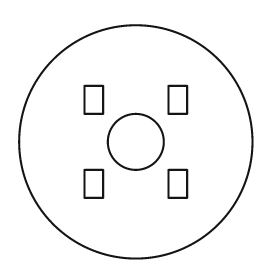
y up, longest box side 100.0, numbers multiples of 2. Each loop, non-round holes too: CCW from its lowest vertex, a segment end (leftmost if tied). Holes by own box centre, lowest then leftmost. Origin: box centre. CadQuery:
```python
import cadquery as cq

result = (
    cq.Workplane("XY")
    .moveTo(0.0, 0.0)
    .circle(50.0)
    .moveTo(-22.0, -24.0)
    .lineTo(-14.0, -24.0)
    .lineTo(-14.0, -12.0)
    .lineTo(-22.0, -12.0)
    .close()
    .moveTo(14.0, -24.0)
    .lineTo(22.0, -24.0)
    .lineTo(22.0, -12.0)
    .lineTo(14.0, -12.0)
    .close()
    .moveTo(0.0, 0.0)
    .circle(12.0)
    .moveTo(-22.0, 12.0)
    .lineTo(-14.0, 12.0)
    .lineTo(-14.0, 24.0)
    .lineTo(-22.0, 24.0)
    .close()
    .moveTo(14.0, 12.0)
    .lineTo(22.0, 12.0)
    .lineTo(22.0, 24.0)
    .lineTo(14.0, 24.0)
    .close()
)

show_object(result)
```